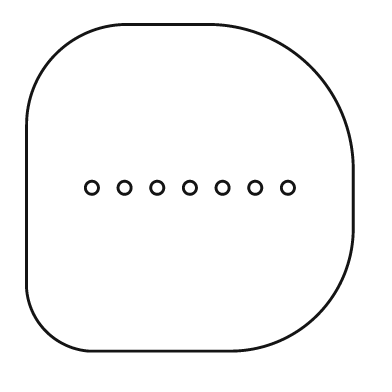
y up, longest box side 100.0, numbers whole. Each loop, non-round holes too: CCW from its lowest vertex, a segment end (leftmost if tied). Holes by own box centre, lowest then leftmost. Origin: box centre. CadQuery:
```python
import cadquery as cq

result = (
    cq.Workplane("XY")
    .moveTo(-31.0, -50.0)
    .lineTo(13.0, -50.0)
    .threePointArc((39.0, -39.0), (50.0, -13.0))
    .lineTo(50.0, 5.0)
    .threePointArc((37.0, 37.0), (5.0, 50.0))
    .lineTo(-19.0, 50.0)
    .threePointArc((-41.0, 41.0), (-50.0, 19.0))
    .lineTo(-50.0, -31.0)
    .threePointArc((-44.0, -44.0), (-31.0, -50.0))
    .close()
    .moveTo(-30.0, 0.0)
    .circle(2.0)
    .moveTo(-20.0, 0.0)
    .circle(2.0)
    .moveTo(-10.0, 0.0)
    .circle(2.0)
    .moveTo(0.0, 0.0)
    .circle(2.0)
    .moveTo(10.0, 0.0)
    .circle(2.0)
    .moveTo(20.0, 0.0)
    .circle(2.0)
    .moveTo(30.0, 0.0)
    .circle(2.0)
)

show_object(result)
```